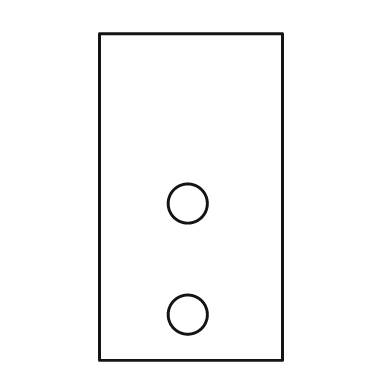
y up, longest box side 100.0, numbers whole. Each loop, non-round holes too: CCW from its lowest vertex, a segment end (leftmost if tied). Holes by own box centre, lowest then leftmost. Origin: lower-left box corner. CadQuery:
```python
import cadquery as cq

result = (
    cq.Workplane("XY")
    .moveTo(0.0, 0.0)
    .lineTo(56.0, 0.0)
    .lineTo(56.0, 100.0)
    .lineTo(0.0, 100.0)
    .close()
    .moveTo(27.0, 14.0)
    .circle(6.0)
    .moveTo(27.0, 48.0)
    .circle(6.0)
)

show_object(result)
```